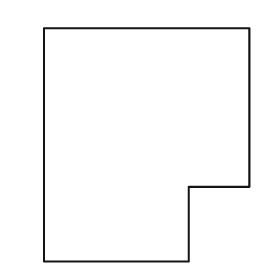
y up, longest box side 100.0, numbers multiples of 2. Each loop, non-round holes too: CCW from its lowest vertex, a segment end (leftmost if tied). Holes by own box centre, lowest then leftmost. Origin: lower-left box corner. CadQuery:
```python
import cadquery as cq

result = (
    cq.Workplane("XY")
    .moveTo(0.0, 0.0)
    .lineTo(62.0, 0.0)
    .lineTo(62.0, 32.0)
    .lineTo(88.0, 32.0)
    .lineTo(88.0, 100.0)
    .lineTo(0.0, 100.0)
    .close()
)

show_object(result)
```